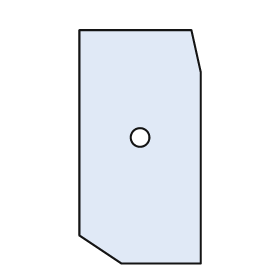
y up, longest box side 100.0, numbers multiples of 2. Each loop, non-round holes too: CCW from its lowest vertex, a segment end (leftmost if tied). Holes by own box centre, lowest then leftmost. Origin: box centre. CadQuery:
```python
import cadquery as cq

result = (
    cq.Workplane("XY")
    .moveTo(-8.0, -50.0)
    .lineTo(26.0, -50.0)
    .lineTo(26.0, 32.0)
    .lineTo(22.0, 50.0)
    .lineTo(-26.0, 50.0)
    .lineTo(-26.0, -38.0)
    .close()
    .moveTo(0.0, 4.0)
    .circle(4.0)
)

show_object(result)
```